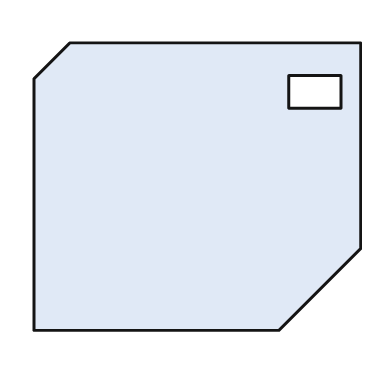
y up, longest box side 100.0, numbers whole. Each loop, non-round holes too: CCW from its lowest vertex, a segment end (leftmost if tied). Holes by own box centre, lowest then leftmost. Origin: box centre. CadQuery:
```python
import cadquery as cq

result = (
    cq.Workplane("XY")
    .moveTo(-50.0, -44.0)
    .lineTo(25.0, -44.0)
    .lineTo(50.0, -19.0)
    .lineTo(50.0, 44.0)
    .lineTo(-39.0, 44.0)
    .lineTo(-50.0, 33.0)
    .close()
    .moveTo(28.0, 24.0)
    .lineTo(44.0, 24.0)
    .lineTo(44.0, 34.0)
    .lineTo(28.0, 34.0)
    .close()
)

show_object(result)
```